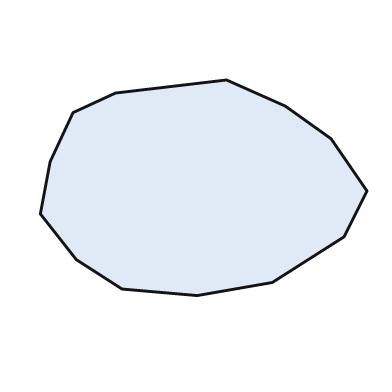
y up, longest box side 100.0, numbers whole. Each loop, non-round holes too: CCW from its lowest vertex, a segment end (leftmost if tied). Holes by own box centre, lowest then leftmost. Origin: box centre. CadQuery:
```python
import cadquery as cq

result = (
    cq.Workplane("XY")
    .moveTo(-2.0, -33.0)
    .lineTo(21.0, -29.0)
    .lineTo(43.0, -15.0)
    .lineTo(50.0, -1.0)
    .lineTo(39.0, 15.0)
    .lineTo(25.0, 25.0)
    .lineTo(7.0, 33.0)
    .lineTo(-27.0, 29.0)
    .lineTo(-40.0, 23.0)
    .lineTo(-47.0, 8.0)
    .lineTo(-50.0, -8.0)
    .lineTo(-39.0, -22.0)
    .lineTo(-25.0, -31.0)
    .close()
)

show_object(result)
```